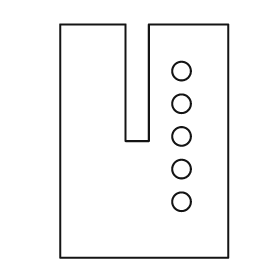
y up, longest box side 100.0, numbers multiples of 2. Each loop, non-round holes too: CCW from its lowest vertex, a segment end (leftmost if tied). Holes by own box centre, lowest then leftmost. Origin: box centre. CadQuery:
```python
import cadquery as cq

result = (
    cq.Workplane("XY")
    .moveTo(-36.0, -50.0)
    .lineTo(36.0, -50.0)
    .lineTo(36.0, 50.0)
    .lineTo(2.0, 50.0)
    .lineTo(2.0, 0.0)
    .lineTo(-8.0, 0.0)
    .lineTo(-8.0, 50.0)
    .lineTo(-36.0, 50.0)
    .close()
    .moveTo(16.0, -26.0)
    .circle(4.0)
    .moveTo(16.0, -12.0)
    .circle(4.0)
    .moveTo(16.0, 2.0)
    .circle(4.0)
    .moveTo(16.0, 16.0)
    .circle(4.0)
    .moveTo(16.0, 30.0)
    .circle(4.0)
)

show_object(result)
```